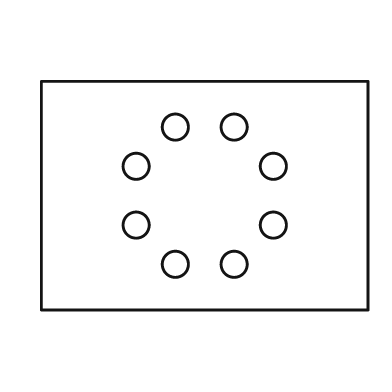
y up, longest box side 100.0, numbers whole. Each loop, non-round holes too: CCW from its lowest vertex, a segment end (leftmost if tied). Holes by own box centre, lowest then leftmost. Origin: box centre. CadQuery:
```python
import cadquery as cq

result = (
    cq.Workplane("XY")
    .moveTo(-50.0, -35.0)
    .lineTo(50.0, -35.0)
    .lineTo(50.0, 35.0)
    .lineTo(-50.0, 35.0)
    .close()
    .moveTo(-9.0, -21.0)
    .circle(4.0)
    .moveTo(9.0, -21.0)
    .circle(4.0)
    .moveTo(-21.0, -9.0)
    .circle(4.0)
    .moveTo(21.0, -9.0)
    .circle(4.0)
    .moveTo(-21.0, 9.0)
    .circle(4.0)
    .moveTo(21.0, 9.0)
    .circle(4.0)
    .moveTo(-9.0, 21.0)
    .circle(4.0)
    .moveTo(9.0, 21.0)
    .circle(4.0)
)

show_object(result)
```